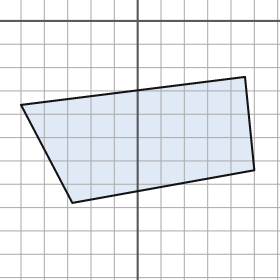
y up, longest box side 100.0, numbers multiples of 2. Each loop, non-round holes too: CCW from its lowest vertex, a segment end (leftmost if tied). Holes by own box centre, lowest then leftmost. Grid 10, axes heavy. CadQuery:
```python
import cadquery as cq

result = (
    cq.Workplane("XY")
    .moveTo(-28.0, -78.0)
    .lineTo(50.0, -64.0)
    .lineTo(46.0, -24.0)
    .lineTo(-50.0, -36.0)
    .close()
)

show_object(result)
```